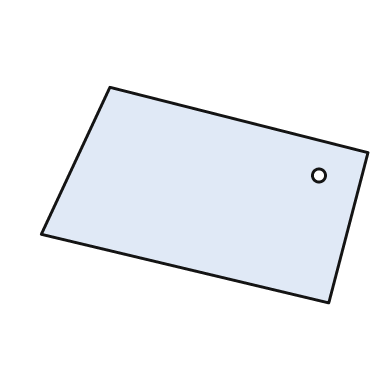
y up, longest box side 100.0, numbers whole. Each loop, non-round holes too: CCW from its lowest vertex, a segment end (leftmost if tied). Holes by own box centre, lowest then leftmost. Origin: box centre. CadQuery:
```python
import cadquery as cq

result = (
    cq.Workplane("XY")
    .moveTo(38.0, -33.0)
    .lineTo(50.0, 13.0)
    .lineTo(-29.0, 33.0)
    .lineTo(-50.0, -12.0)
    .close()
    .moveTo(35.0, 6.0)
    .circle(2.0)
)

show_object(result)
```